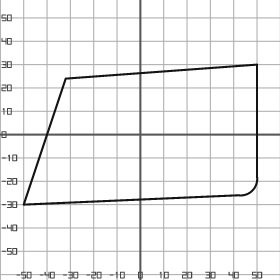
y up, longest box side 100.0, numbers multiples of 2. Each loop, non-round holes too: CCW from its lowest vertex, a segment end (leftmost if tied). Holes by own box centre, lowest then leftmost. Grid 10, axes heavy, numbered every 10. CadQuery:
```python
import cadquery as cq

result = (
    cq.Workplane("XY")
    .moveTo(-50.0, -30.0)
    .lineTo(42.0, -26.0)
    .threePointArc((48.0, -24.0), (50.0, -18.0))
    .lineTo(50.0, 30.0)
    .lineTo(-32.0, 24.0)
    .close()
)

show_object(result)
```